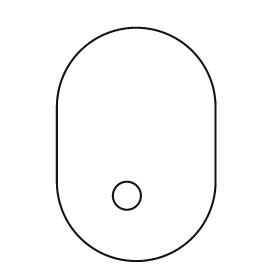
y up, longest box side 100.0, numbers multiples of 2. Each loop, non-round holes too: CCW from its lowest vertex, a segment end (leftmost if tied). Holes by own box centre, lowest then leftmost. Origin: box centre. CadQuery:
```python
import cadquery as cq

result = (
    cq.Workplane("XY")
    .moveTo(-34.0, -16.0)
    .threePointArc((0.0, -50.0), (34.0, -16.0))
    .lineTo(34.0, 16.0)
    .threePointArc((0.0, 50.0), (-34.0, 16.0))
    .close()
    .moveTo(-4.0, -22.0)
    .circle(6.0)
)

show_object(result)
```